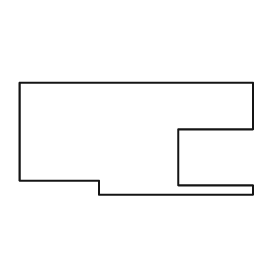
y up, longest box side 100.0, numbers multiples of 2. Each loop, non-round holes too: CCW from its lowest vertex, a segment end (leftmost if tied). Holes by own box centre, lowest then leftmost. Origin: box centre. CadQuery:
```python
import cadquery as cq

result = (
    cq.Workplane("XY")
    .moveTo(-16.0, -24.0)
    .lineTo(50.0, -24.0)
    .lineTo(50.0, -20.0)
    .lineTo(18.0, -20.0)
    .lineTo(18.0, 4.0)
    .lineTo(50.0, 4.0)
    .lineTo(50.0, 24.0)
    .lineTo(-50.0, 24.0)
    .lineTo(-50.0, -18.0)
    .lineTo(-16.0, -18.0)
    .close()
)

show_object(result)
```